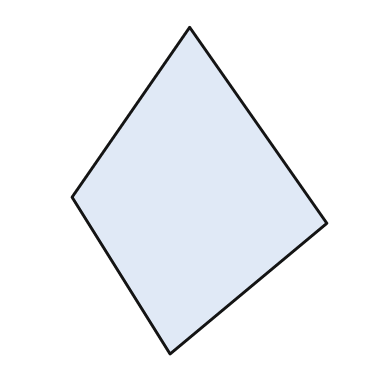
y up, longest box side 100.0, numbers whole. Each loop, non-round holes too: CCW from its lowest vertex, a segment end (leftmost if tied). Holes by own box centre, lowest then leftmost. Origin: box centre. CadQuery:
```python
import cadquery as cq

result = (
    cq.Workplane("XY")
    .moveTo(-9.0, -50.0)
    .lineTo(39.0, -10.0)
    .lineTo(-3.0, 50.0)
    .lineTo(-39.0, -2.0)
    .close()
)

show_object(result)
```